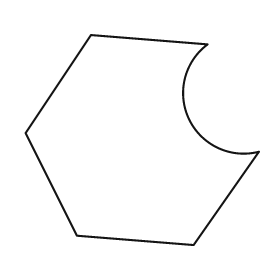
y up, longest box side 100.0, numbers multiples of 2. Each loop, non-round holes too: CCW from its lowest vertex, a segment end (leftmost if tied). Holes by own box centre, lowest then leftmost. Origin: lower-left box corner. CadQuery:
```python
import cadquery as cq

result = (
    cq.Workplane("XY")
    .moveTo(72.0, 0.0)
    .lineTo(100.0, 40.0)
    .threePointArc((70.0, 54.0), (78.0, 86.0))
    .lineTo(28.0, 90.0)
    .lineTo(0.0, 48.0)
    .lineTo(22.0, 4.0)
    .close()
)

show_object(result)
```